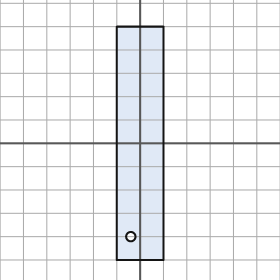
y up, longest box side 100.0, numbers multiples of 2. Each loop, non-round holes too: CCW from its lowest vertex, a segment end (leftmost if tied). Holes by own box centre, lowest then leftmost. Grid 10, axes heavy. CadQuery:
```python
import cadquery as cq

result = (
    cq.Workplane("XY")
    .moveTo(-10.0, -50.0)
    .lineTo(10.0, -50.0)
    .lineTo(10.0, 50.0)
    .lineTo(-10.0, 50.0)
    .close()
    .moveTo(-4.0, -40.0)
    .circle(2.0)
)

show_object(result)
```